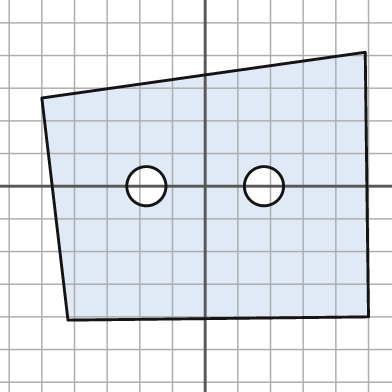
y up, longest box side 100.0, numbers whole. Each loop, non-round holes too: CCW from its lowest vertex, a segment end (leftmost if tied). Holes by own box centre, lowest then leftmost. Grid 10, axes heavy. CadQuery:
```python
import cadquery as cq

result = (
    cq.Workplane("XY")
    .moveTo(-42.0, -41.0)
    .lineTo(50.0, -40.0)
    .lineTo(49.0, 41.0)
    .lineTo(-50.0, 27.0)
    .close()
    .moveTo(-18.0, 0.0)
    .circle(6.0)
    .moveTo(18.0, 0.0)
    .circle(6.0)
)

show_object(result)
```